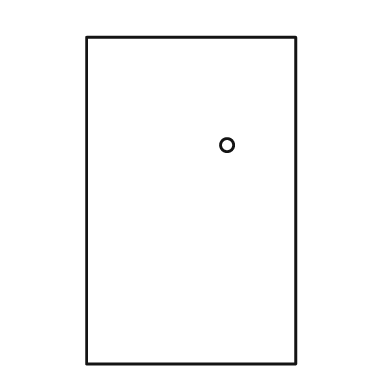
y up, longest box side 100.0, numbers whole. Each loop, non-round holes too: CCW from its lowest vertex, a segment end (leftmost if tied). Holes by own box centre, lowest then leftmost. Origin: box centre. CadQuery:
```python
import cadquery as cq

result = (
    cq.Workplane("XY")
    .moveTo(-32.0, -50.0)
    .lineTo(32.0, -50.0)
    .lineTo(32.0, 50.0)
    .lineTo(-32.0, 50.0)
    .close()
    .moveTo(11.0, 17.0)
    .circle(2.0)
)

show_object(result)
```